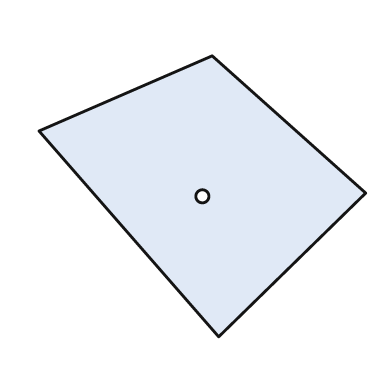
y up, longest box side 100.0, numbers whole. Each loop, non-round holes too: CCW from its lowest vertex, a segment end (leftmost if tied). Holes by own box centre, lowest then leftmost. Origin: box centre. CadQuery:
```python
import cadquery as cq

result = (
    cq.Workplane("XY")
    .moveTo(5.0, -43.0)
    .lineTo(50.0, 1.0)
    .lineTo(3.0, 43.0)
    .lineTo(-50.0, 20.0)
    .close()
    .moveTo(0.0, 0.0)
    .circle(2.0)
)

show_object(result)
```